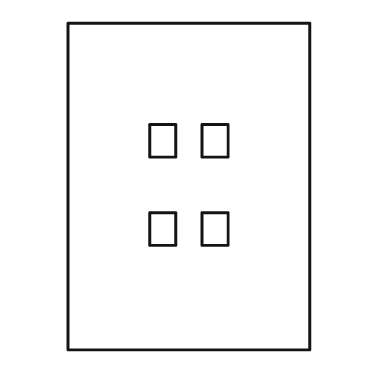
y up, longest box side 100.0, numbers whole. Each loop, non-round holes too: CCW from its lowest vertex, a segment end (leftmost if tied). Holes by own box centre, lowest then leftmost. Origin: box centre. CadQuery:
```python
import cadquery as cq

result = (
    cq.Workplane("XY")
    .moveTo(-37.0, -50.0)
    .lineTo(37.0, -50.0)
    .lineTo(37.0, 50.0)
    .lineTo(-37.0, 50.0)
    .close()
    .moveTo(-12.0, -18.0)
    .lineTo(-4.0, -18.0)
    .lineTo(-4.0, -8.0)
    .lineTo(-12.0, -8.0)
    .close()
    .moveTo(4.0, -18.0)
    .lineTo(12.0, -18.0)
    .lineTo(12.0, -8.0)
    .lineTo(4.0, -8.0)
    .close()
    .moveTo(-12.0, 9.0)
    .lineTo(-4.0, 9.0)
    .lineTo(-4.0, 19.0)
    .lineTo(-12.0, 19.0)
    .close()
    .moveTo(4.0, 9.0)
    .lineTo(12.0, 9.0)
    .lineTo(12.0, 19.0)
    .lineTo(4.0, 19.0)
    .close()
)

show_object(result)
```